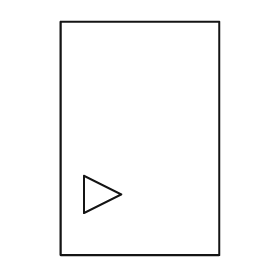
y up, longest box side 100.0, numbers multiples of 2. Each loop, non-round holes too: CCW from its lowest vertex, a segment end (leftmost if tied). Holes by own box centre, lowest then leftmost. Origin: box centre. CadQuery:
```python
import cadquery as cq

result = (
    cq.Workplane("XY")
    .moveTo(-34.0, -50.0)
    .lineTo(34.0, -50.0)
    .lineTo(34.0, 50.0)
    .lineTo(-34.0, 50.0)
    .close()
    .moveTo(-24.0, -32.0)
    .lineTo(-8.0, -24.0)
    .lineTo(-24.0, -16.0)
    .close()
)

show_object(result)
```